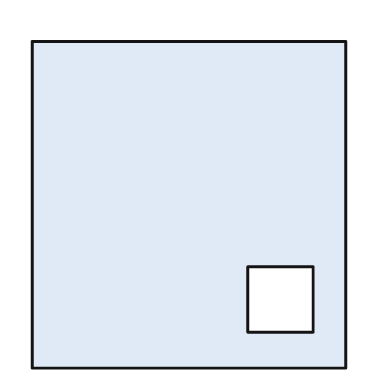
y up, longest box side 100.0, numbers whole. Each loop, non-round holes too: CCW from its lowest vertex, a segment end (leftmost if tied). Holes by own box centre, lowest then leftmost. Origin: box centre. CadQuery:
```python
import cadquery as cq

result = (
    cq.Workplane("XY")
    .moveTo(-48.0, -50.0)
    .lineTo(48.0, -50.0)
    .lineTo(48.0, 50.0)
    .lineTo(-48.0, 50.0)
    .close()
    .moveTo(18.0, -39.0)
    .lineTo(38.0, -39.0)
    .lineTo(38.0, -19.0)
    .lineTo(18.0, -19.0)
    .close()
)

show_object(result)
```